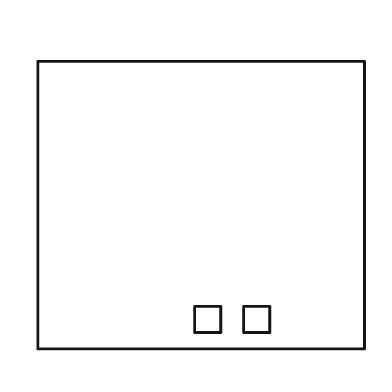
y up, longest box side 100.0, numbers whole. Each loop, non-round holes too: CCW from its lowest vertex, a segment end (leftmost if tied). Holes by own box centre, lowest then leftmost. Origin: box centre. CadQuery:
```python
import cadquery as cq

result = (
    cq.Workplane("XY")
    .moveTo(-50.0, -44.0)
    .lineTo(50.0, -44.0)
    .lineTo(50.0, 44.0)
    .lineTo(-50.0, 44.0)
    .close()
    .moveTo(-2.0, -39.0)
    .lineTo(6.0, -39.0)
    .lineTo(6.0, -31.0)
    .lineTo(-2.0, -31.0)
    .close()
    .moveTo(13.0, -39.0)
    .lineTo(21.0, -39.0)
    .lineTo(21.0, -31.0)
    .lineTo(13.0, -31.0)
    .close()
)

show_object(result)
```